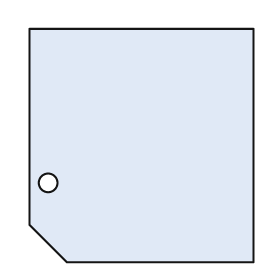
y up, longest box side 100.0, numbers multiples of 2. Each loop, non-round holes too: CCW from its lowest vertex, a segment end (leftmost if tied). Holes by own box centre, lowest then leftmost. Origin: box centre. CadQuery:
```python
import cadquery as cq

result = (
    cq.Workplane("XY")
    .moveTo(-32.0, -50.0)
    .lineTo(48.0, -50.0)
    .lineTo(48.0, 50.0)
    .lineTo(-48.0, 50.0)
    .lineTo(-48.0, -34.0)
    .close()
    .moveTo(-40.0, -16.0)
    .circle(4.0)
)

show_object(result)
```